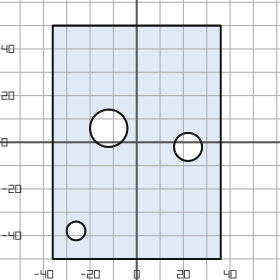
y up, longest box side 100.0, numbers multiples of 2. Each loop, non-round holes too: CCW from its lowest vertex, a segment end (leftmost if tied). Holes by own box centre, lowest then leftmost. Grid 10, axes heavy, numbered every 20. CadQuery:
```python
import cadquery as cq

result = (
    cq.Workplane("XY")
    .moveTo(-36.0, -50.0)
    .lineTo(36.0, -50.0)
    .lineTo(36.0, 50.0)
    .lineTo(-36.0, 50.0)
    .close()
    .moveTo(-26.0, -38.0)
    .circle(4.0)
    .moveTo(22.0, -2.0)
    .circle(6.0)
    .moveTo(-12.0, 6.0)
    .circle(8.0)
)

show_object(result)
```